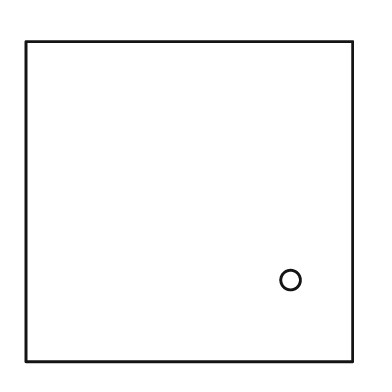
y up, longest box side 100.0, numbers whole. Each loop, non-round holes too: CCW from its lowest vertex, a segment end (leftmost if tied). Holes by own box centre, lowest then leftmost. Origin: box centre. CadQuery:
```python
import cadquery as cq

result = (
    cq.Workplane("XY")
    .moveTo(-50.0, -49.0)
    .lineTo(50.0, -49.0)
    .lineTo(50.0, 49.0)
    .lineTo(-50.0, 49.0)
    .close()
    .moveTo(31.0, -24.0)
    .circle(3.0)
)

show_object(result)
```